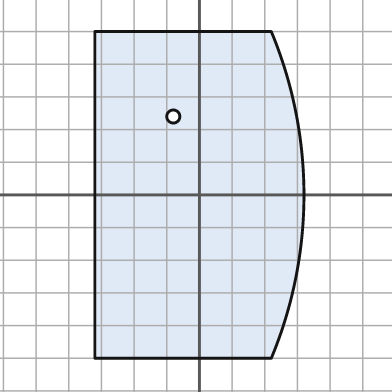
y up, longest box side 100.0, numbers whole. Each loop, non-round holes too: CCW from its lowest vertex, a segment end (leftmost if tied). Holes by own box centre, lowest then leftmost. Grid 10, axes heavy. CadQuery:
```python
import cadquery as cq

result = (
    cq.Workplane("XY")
    .moveTo(-32.0, -50.0)
    .lineTo(22.0, -50.0)
    .threePointArc((32.0, 0.0), (22.0, 50.0))
    .lineTo(-32.0, 50.0)
    .close()
    .moveTo(-8.0, 24.0)
    .circle(2.0)
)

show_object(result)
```